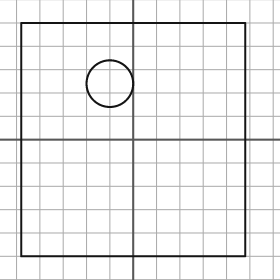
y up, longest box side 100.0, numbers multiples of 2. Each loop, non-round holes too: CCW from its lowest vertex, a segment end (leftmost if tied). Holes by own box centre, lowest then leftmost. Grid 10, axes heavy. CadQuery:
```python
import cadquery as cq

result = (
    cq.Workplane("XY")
    .moveTo(-48.0, -50.0)
    .lineTo(48.0, -50.0)
    .lineTo(48.0, 50.0)
    .lineTo(-48.0, 50.0)
    .close()
    .moveTo(-10.0, 24.0)
    .circle(10.0)
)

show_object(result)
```